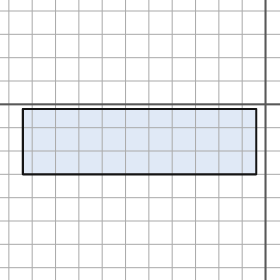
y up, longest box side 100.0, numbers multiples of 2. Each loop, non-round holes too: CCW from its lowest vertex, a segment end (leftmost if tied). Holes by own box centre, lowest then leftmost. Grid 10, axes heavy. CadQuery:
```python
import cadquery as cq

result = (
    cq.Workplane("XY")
    .moveTo(-104.0, -30.0)
    .lineTo(-4.0, -30.0)
    .lineTo(-4.0, -2.0)
    .lineTo(-104.0, -2.0)
    .close()
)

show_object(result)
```